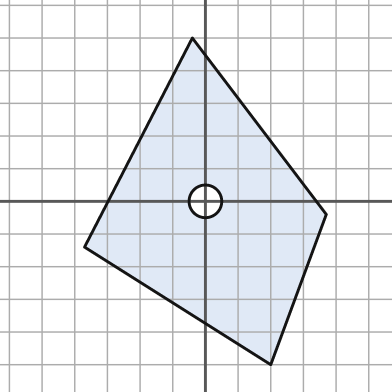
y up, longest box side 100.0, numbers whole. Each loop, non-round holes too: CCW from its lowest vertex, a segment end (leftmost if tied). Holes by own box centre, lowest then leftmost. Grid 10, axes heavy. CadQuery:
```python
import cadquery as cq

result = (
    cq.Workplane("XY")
    .moveTo(20.0, -50.0)
    .lineTo(37.0, -4.0)
    .lineTo(-4.0, 50.0)
    .lineTo(-37.0, -14.0)
    .close()
    .moveTo(0.0, 0.0)
    .circle(5.0)
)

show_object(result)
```